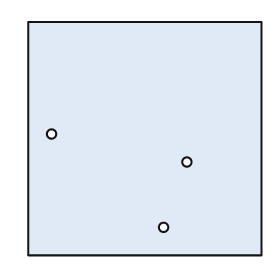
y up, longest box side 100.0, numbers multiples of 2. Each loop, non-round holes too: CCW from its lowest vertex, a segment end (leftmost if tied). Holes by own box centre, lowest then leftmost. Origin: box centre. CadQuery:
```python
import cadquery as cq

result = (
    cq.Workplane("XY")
    .moveTo(-50.0, -50.0)
    .lineTo(50.0, -50.0)
    .lineTo(50.0, 50.0)
    .lineTo(-50.0, 50.0)
    .close()
    .moveTo(8.0, -38.0)
    .circle(2.0)
    .moveTo(18.0, -10.0)
    .circle(2.0)
    .moveTo(-40.0, 2.0)
    .circle(2.0)
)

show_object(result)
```